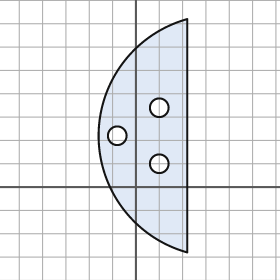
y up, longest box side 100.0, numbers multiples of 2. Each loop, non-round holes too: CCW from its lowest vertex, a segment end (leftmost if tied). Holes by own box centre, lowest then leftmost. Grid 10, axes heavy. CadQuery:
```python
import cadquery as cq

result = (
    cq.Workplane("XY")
    .moveTo(22.0, -28.0)
    .lineTo(22.0, 72.0)
    .threePointArc((-16.0, 22.0), (22.0, -28.0))
    .close()
    .moveTo(10.0, 10.0)
    .circle(4.0)
    .moveTo(-8.0, 22.0)
    .circle(4.0)
    .moveTo(10.0, 34.0)
    .circle(4.0)
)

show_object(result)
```